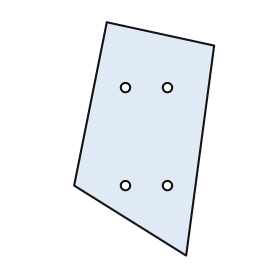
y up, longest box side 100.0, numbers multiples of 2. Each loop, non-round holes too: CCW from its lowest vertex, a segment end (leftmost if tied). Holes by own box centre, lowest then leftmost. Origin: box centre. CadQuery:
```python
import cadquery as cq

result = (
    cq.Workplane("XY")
    .moveTo(18.0, -50.0)
    .lineTo(30.0, 40.0)
    .lineTo(-16.0, 50.0)
    .lineTo(-30.0, -20.0)
    .close()
    .moveTo(-8.0, -20.0)
    .circle(2.0)
    .moveTo(10.0, -20.0)
    .circle(2.0)
    .moveTo(-8.0, 22.0)
    .circle(2.0)
    .moveTo(10.0, 22.0)
    .circle(2.0)
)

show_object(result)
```